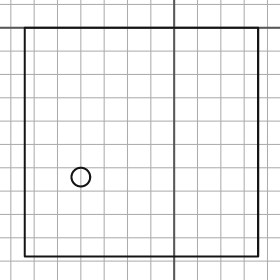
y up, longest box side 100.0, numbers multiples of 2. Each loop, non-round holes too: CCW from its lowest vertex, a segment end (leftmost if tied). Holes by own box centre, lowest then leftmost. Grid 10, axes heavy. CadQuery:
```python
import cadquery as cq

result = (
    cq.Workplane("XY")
    .moveTo(-64.0, -98.0)
    .lineTo(36.0, -98.0)
    .lineTo(36.0, 0.0)
    .lineTo(-64.0, 0.0)
    .close()
    .moveTo(-40.0, -64.0)
    .circle(4.0)
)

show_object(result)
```